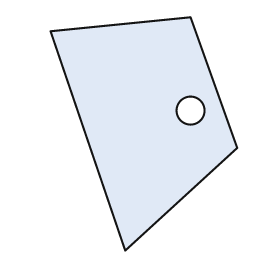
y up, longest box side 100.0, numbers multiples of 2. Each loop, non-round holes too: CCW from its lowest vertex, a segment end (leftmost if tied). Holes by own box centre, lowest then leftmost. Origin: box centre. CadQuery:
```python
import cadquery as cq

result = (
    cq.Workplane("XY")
    .moveTo(-8.0, -50.0)
    .lineTo(40.0, -6.0)
    .lineTo(20.0, 50.0)
    .lineTo(-40.0, 44.0)
    .close()
    .moveTo(20.0, 10.0)
    .circle(6.0)
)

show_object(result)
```